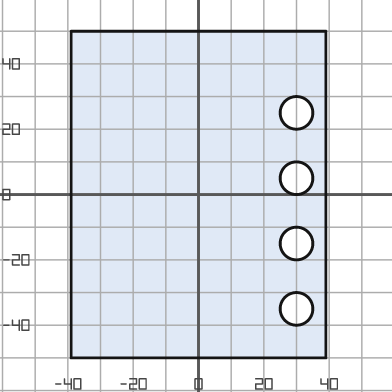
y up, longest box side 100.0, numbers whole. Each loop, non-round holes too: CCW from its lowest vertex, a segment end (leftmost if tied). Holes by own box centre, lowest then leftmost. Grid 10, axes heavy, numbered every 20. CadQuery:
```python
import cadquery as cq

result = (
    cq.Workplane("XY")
    .moveTo(-39.0, -50.0)
    .lineTo(39.0, -50.0)
    .lineTo(39.0, 50.0)
    .lineTo(-39.0, 50.0)
    .close()
    .moveTo(30.0, -35.0)
    .circle(5.0)
    .moveTo(30.0, -15.0)
    .circle(5.0)
    .moveTo(30.0, 5.0)
    .circle(5.0)
    .moveTo(30.0, 25.0)
    .circle(5.0)
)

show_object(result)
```